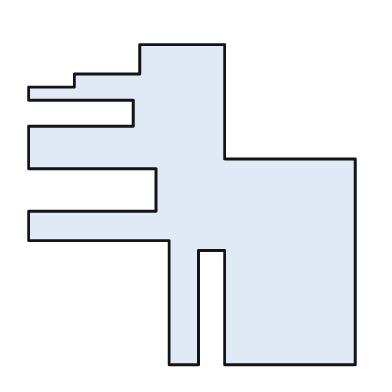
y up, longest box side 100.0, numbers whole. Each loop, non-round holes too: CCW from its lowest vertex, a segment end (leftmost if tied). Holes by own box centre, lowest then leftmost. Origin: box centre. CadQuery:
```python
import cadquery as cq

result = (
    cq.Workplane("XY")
    .moveTo(-7.0, -49.0)
    .lineTo(2.0, -49.0)
    .lineTo(2.0, -14.0)
    .lineTo(10.0, -14.0)
    .lineTo(10.0, -49.0)
    .lineTo(50.0, -49.0)
    .lineTo(50.0, 14.0)
    .lineTo(10.0, 14.0)
    .lineTo(10.0, 49.0)
    .lineTo(-16.0, 49.0)
    .lineTo(-16.0, 40.0)
    .lineTo(-36.0, 40.0)
    .lineTo(-36.0, 36.0)
    .lineTo(-50.0, 36.0)
    .lineTo(-50.0, 32.0)
    .lineTo(-18.0, 32.0)
    .lineTo(-18.0, 24.0)
    .lineTo(-50.0, 24.0)
    .lineTo(-50.0, 11.0)
    .lineTo(-11.0, 11.0)
    .lineTo(-11.0, -2.0)
    .lineTo(-50.0, -2.0)
    .lineTo(-50.0, -11.0)
    .lineTo(-7.0, -11.0)
    .close()
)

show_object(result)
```